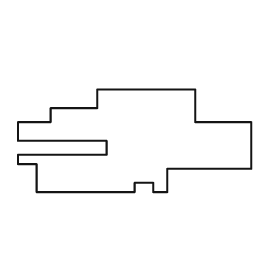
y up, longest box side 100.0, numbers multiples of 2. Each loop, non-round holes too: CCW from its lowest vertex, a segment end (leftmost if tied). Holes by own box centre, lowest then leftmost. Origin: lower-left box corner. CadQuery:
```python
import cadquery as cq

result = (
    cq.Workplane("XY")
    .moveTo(8.0, 0.0)
    .lineTo(50.0, 0.0)
    .lineTo(50.0, 4.0)
    .lineTo(58.0, 4.0)
    .lineTo(58.0, 0.0)
    .lineTo(64.0, 0.0)
    .lineTo(64.0, 10.0)
    .lineTo(100.0, 10.0)
    .lineTo(100.0, 30.0)
    .lineTo(76.0, 30.0)
    .lineTo(76.0, 44.0)
    .lineTo(34.0, 44.0)
    .lineTo(34.0, 36.0)
    .lineTo(14.0, 36.0)
    .lineTo(14.0, 30.0)
    .lineTo(0.0, 30.0)
    .lineTo(0.0, 22.0)
    .lineTo(38.0, 22.0)
    .lineTo(38.0, 16.0)
    .lineTo(0.0, 16.0)
    .lineTo(0.0, 12.0)
    .lineTo(8.0, 12.0)
    .close()
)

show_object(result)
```